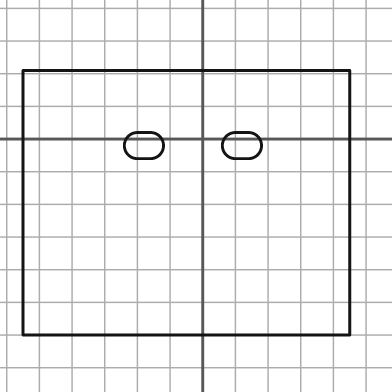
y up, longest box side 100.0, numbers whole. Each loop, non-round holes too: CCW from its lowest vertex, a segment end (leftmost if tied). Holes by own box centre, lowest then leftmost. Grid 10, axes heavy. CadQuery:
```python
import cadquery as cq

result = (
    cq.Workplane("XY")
    .moveTo(-55.0, -60.0)
    .lineTo(45.0, -60.0)
    .lineTo(45.0, 21.0)
    .lineTo(-55.0, 21.0)
    .close()
    .moveTo(-20.0, -6.0)
    .lineTo(-16.0, -6.0)
    .threePointArc((-12.0, -2.0), (-16.0, 2.0))
    .lineTo(-20.0, 2.0)
    .threePointArc((-24.0, -2.0), (-20.0, -6.0))
    .close()
    .moveTo(10.0, -6.0)
    .lineTo(14.0, -6.0)
    .threePointArc((18.0, -2.0), (14.0, 2.0))
    .lineTo(10.0, 2.0)
    .threePointArc((6.0, -2.0), (10.0, -6.0))
    .close()
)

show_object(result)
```